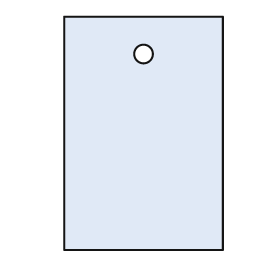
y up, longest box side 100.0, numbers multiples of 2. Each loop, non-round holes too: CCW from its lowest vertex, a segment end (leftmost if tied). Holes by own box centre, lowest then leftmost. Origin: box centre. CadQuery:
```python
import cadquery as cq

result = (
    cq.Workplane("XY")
    .moveTo(-34.0, -50.0)
    .lineTo(34.0, -50.0)
    .lineTo(34.0, 50.0)
    .lineTo(-34.0, 50.0)
    .close()
    .moveTo(0.0, 34.0)
    .circle(4.0)
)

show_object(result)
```